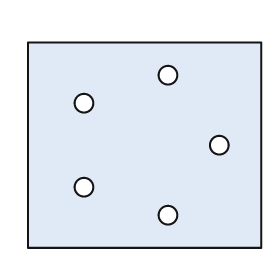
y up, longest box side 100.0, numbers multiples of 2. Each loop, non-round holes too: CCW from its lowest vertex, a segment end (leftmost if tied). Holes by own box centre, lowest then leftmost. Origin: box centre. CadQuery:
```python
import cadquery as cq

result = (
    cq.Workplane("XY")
    .moveTo(-50.0, -44.0)
    .lineTo(50.0, -44.0)
    .lineTo(50.0, 44.0)
    .lineTo(-50.0, 44.0)
    .close()
    .moveTo(10.0, -30.0)
    .circle(4.0)
    .moveTo(-26.0, -18.0)
    .circle(4.0)
    .moveTo(32.0, 0.0)
    .circle(4.0)
    .moveTo(-26.0, 18.0)
    .circle(4.0)
    .moveTo(10.0, 30.0)
    .circle(4.0)
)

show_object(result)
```